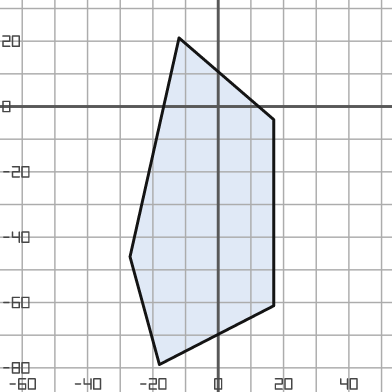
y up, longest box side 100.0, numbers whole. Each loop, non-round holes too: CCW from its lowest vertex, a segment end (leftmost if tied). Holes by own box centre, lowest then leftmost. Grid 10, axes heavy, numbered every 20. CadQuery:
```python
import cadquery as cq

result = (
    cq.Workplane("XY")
    .moveTo(-18.0, -79.0)
    .lineTo(17.0, -61.0)
    .lineTo(17.0, -4.0)
    .lineTo(-12.0, 21.0)
    .lineTo(-27.0, -46.0)
    .close()
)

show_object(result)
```